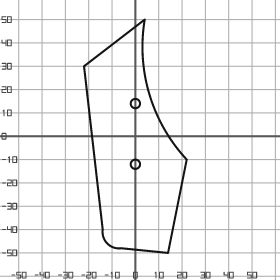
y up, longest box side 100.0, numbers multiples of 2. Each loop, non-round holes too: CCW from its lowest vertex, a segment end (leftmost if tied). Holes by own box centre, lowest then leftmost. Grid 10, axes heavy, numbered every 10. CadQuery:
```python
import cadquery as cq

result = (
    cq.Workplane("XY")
    .moveTo(14.0, -50.0)
    .lineTo(22.0, -10.0)
    .threePointArc((6.0, 18.0), (4.0, 50.0))
    .lineTo(-22.0, 30.0)
    .lineTo(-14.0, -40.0)
    .threePointArc((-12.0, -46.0), (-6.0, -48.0))
    .close()
    .moveTo(0.0, -12.0)
    .circle(2.0)
    .moveTo(0.0, 14.0)
    .circle(2.0)
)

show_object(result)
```